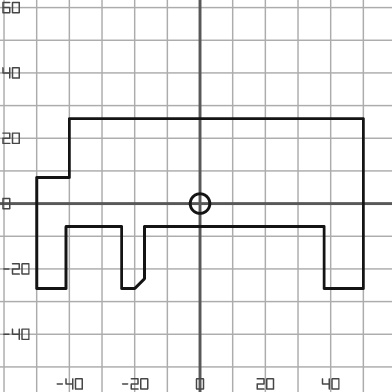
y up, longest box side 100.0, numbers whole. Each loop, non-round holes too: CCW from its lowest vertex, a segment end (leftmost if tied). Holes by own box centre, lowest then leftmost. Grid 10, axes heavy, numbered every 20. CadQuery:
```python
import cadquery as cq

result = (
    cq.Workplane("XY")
    .moveTo(-50.0, -26.0)
    .lineTo(-41.0, -26.0)
    .lineTo(-41.0, -7.0)
    .lineTo(-24.0, -7.0)
    .lineTo(-24.0, -26.0)
    .lineTo(-20.0, -26.0)
    .lineTo(-17.0, -23.0)
    .lineTo(-17.0, -7.0)
    .lineTo(38.0, -7.0)
    .lineTo(38.0, -26.0)
    .lineTo(50.0, -26.0)
    .lineTo(50.0, 26.0)
    .lineTo(-40.0, 26.0)
    .lineTo(-40.0, 8.0)
    .lineTo(-50.0, 8.0)
    .close()
    .moveTo(0.0, 0.0)
    .circle(3.0)
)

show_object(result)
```